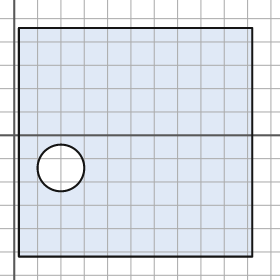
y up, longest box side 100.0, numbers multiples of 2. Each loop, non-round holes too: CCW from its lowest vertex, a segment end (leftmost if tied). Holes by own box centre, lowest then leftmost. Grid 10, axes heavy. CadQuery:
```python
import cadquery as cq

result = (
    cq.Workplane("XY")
    .moveTo(2.0, -52.0)
    .lineTo(102.0, -52.0)
    .lineTo(102.0, 46.0)
    .lineTo(2.0, 46.0)
    .close()
    .moveTo(20.0, -14.0)
    .circle(10.0)
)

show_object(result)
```